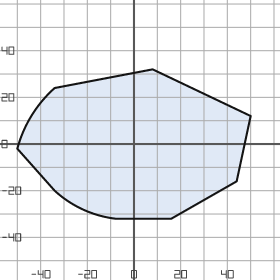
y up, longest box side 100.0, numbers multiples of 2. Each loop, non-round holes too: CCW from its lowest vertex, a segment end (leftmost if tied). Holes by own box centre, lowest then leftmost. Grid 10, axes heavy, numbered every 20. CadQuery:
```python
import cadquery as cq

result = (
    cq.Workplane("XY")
    .moveTo(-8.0, -32.0)
    .lineTo(16.0, -32.0)
    .lineTo(44.0, -16.0)
    .lineTo(50.0, 12.0)
    .lineTo(8.0, 32.0)
    .lineTo(-34.0, 24.0)
    .threePointArc((-44.0, 12.0), (-50.0, -2.0))
    .lineTo(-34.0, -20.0)
    .threePointArc((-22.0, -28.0), (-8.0, -32.0))
    .close()
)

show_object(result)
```